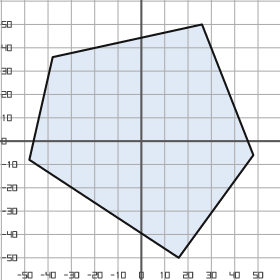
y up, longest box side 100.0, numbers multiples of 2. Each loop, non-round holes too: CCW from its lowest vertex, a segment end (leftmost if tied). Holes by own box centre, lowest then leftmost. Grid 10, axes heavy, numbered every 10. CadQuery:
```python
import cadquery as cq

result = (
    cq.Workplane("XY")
    .moveTo(16.0, -50.0)
    .lineTo(48.0, -6.0)
    .lineTo(26.0, 50.0)
    .lineTo(-38.0, 36.0)
    .lineTo(-48.0, -8.0)
    .close()
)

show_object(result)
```